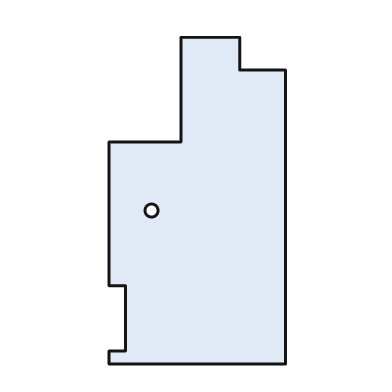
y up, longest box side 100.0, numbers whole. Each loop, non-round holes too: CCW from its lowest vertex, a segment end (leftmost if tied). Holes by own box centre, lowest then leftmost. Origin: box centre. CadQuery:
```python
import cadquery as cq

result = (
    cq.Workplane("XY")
    .moveTo(-27.0, -50.0)
    .lineTo(27.0, -50.0)
    .lineTo(27.0, 40.0)
    .lineTo(13.0, 40.0)
    .lineTo(13.0, 50.0)
    .lineTo(-5.0, 50.0)
    .lineTo(-5.0, 18.0)
    .lineTo(-27.0, 18.0)
    .lineTo(-27.0, -26.0)
    .lineTo(-22.0, -26.0)
    .lineTo(-22.0, -46.0)
    .lineTo(-27.0, -46.0)
    .close()
    .moveTo(-14.0, -3.0)
    .circle(2.0)
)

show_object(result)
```